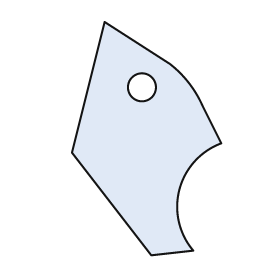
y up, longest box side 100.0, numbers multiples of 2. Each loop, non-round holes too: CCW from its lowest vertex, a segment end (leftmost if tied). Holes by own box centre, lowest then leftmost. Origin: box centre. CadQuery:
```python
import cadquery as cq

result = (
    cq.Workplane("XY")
    .moveTo(2.0, -50.0)
    .lineTo(20.0, -48.0)
    .threePointArc((14.0, -22.0), (32.0, -2.0))
    .lineTo(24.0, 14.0)
    .threePointArc((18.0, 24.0), (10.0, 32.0))
    .lineTo(-18.0, 50.0)
    .lineTo(-32.0, -6.0)
    .close()
    .moveTo(-2.0, 22.0)
    .circle(6.0)
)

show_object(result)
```